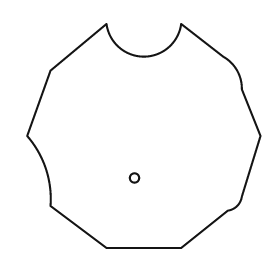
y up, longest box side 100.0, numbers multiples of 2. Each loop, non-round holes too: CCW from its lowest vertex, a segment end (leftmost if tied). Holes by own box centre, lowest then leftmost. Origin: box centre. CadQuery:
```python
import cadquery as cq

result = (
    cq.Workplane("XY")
    .moveTo(-16.0, -48.0)
    .lineTo(16.0, -48.0)
    .lineTo(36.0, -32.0)
    .threePointArc((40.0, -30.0), (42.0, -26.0))
    .lineTo(50.0, 0.0)
    .lineTo(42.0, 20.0)
    .threePointArc((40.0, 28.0), (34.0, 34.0))
    .lineTo(16.0, 48.0)
    .threePointArc((0.0, 34.0), (-16.0, 48.0))
    .lineTo(-40.0, 28.0)
    .lineTo(-50.0, 0.0)
    .threePointArc((-42.0, -14.0), (-40.0, -30.0))
    .close()
    .moveTo(-4.0, -18.0)
    .circle(2.0)
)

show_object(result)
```